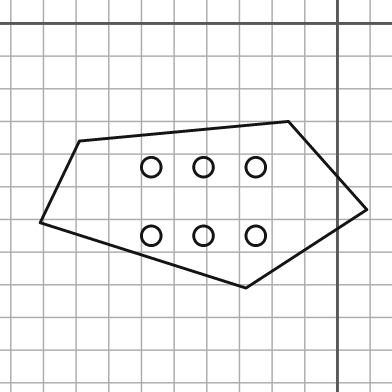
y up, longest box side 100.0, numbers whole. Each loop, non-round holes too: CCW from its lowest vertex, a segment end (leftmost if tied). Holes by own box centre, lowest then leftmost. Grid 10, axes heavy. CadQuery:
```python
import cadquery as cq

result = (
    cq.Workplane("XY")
    .moveTo(-28.0, -81.0)
    .lineTo(9.0, -57.0)
    .lineTo(-15.0, -30.0)
    .lineTo(-79.0, -36.0)
    .lineTo(-91.0, -61.0)
    .close()
    .moveTo(-57.0, -65.0)
    .circle(3.0)
    .moveTo(-41.0, -65.0)
    .circle(3.0)
    .moveTo(-25.0, -65.0)
    .circle(3.0)
    .moveTo(-57.0, -44.0)
    .circle(3.0)
    .moveTo(-41.0, -44.0)
    .circle(3.0)
    .moveTo(-25.0, -44.0)
    .circle(3.0)
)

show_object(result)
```